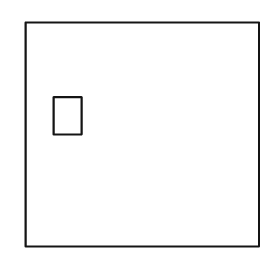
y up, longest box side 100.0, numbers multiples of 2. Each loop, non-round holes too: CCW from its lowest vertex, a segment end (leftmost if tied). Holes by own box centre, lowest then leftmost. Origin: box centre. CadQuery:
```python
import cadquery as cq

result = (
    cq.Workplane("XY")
    .moveTo(-50.0, -48.0)
    .lineTo(50.0, -48.0)
    .lineTo(50.0, 48.0)
    .lineTo(-50.0, 48.0)
    .close()
    .moveTo(-38.0, 0.0)
    .lineTo(-26.0, 0.0)
    .lineTo(-26.0, 16.0)
    .lineTo(-38.0, 16.0)
    .close()
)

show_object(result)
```